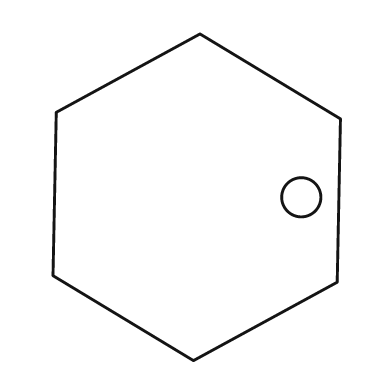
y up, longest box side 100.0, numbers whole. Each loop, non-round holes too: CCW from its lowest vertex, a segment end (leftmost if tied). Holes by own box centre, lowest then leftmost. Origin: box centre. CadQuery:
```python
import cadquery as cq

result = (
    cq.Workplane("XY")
    .moveTo(-1.0, -50.0)
    .lineTo(43.0, -26.0)
    .lineTo(44.0, 24.0)
    .lineTo(1.0, 50.0)
    .lineTo(-43.0, 26.0)
    .lineTo(-44.0, -24.0)
    .close()
    .moveTo(32.0, 0.0)
    .circle(6.0)
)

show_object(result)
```